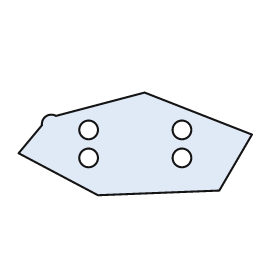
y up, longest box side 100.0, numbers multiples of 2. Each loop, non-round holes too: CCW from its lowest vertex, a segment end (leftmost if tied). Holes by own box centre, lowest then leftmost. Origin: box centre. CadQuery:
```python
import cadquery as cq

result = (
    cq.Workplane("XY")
    .moveTo(-16.0, -22.0)
    .lineTo(36.0, -20.0)
    .lineTo(50.0, 4.0)
    .lineTo(4.0, 22.0)
    .lineTo(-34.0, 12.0)
    .threePointArc((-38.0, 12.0), (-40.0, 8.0))
    .lineTo(-50.0, -4.0)
    .close()
    .moveTo(-20.0, -6.0)
    .circle(4.0)
    .moveTo(20.0, -6.0)
    .circle(4.0)
    .moveTo(-20.0, 6.0)
    .circle(4.0)
    .moveTo(20.0, 6.0)
    .circle(4.0)
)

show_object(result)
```